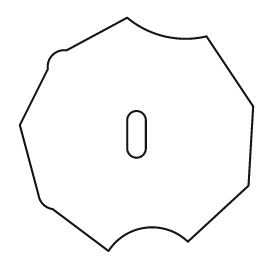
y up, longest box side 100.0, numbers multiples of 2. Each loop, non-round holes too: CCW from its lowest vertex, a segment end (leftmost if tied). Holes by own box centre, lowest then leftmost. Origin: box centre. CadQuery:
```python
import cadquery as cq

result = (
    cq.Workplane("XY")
    .moveTo(-12.0, -50.0)
    .threePointArc((4.0, -40.0), (22.0, -46.0))
    .lineTo(48.0, -22.0)
    .lineTo(50.0, 12.0)
    .lineTo(30.0, 42.0)
    .threePointArc((12.0, 42.0), (-4.0, 50.0))
    .lineTo(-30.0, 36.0)
    .threePointArc((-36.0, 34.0), (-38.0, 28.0))
    .lineTo(-50.0, 4.0)
    .lineTo(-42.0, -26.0)
    .threePointArc((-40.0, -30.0), (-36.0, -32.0))
    .close()
    .moveTo(-4.0, -6.0)
    .threePointArc((0.0, -10.0), (4.0, -6.0))
    .lineTo(4.0, 6.0)
    .threePointArc((0.0, 10.0), (-4.0, 6.0))
    .close()
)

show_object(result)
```